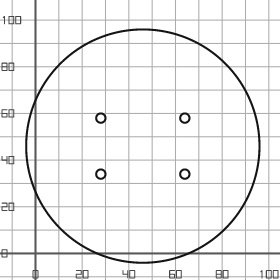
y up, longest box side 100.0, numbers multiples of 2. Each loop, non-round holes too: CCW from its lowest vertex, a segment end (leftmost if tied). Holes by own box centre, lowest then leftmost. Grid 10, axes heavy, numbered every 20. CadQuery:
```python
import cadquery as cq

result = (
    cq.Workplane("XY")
    .moveTo(46.0, 46.0)
    .circle(50.0)
    .moveTo(28.0, 34.0)
    .circle(2.0)
    .moveTo(64.0, 34.0)
    .circle(2.0)
    .moveTo(28.0, 58.0)
    .circle(2.0)
    .moveTo(64.0, 58.0)
    .circle(2.0)
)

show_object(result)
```